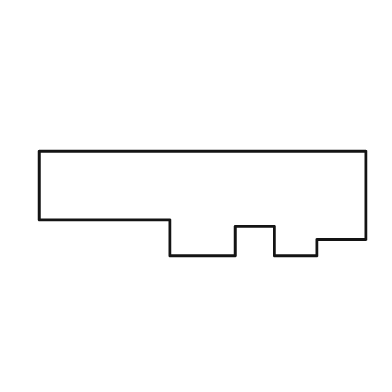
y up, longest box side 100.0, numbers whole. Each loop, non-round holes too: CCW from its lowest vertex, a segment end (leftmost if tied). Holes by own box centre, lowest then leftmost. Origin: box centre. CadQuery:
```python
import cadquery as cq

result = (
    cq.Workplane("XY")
    .moveTo(-10.0, -16.0)
    .lineTo(10.0, -16.0)
    .lineTo(10.0, -7.0)
    .lineTo(22.0, -7.0)
    .lineTo(22.0, -16.0)
    .lineTo(35.0, -16.0)
    .lineTo(35.0, -11.0)
    .lineTo(50.0, -11.0)
    .lineTo(50.0, 16.0)
    .lineTo(-50.0, 16.0)
    .lineTo(-50.0, -5.0)
    .lineTo(-10.0, -5.0)
    .close()
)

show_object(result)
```